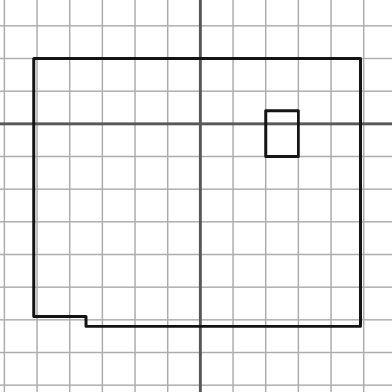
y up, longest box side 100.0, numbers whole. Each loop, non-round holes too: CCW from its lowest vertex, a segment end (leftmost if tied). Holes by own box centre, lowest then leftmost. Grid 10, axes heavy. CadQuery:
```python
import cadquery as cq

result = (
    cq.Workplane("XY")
    .moveTo(-35.0, -62.0)
    .lineTo(49.0, -62.0)
    .lineTo(49.0, 20.0)
    .lineTo(-51.0, 20.0)
    .lineTo(-51.0, -59.0)
    .lineTo(-35.0, -59.0)
    .close()
    .moveTo(20.0, -10.0)
    .lineTo(30.0, -10.0)
    .lineTo(30.0, 4.0)
    .lineTo(20.0, 4.0)
    .close()
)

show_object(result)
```